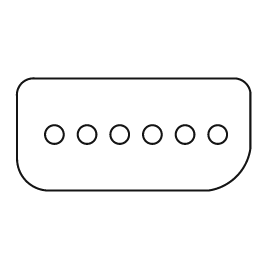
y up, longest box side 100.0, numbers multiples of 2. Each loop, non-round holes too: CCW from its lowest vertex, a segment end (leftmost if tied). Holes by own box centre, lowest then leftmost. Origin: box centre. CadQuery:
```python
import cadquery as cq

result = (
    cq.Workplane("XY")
    .moveTo(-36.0, -24.0)
    .lineTo(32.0, -24.0)
    .threePointArc((44.0, -18.0), (50.0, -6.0))
    .lineTo(50.0, 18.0)
    .threePointArc((48.0, 22.0), (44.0, 24.0))
    .lineTo(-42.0, 24.0)
    .threePointArc((-48.0, 22.0), (-50.0, 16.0))
    .lineTo(-50.0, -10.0)
    .threePointArc((-46.0, -20.0), (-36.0, -24.0))
    .close()
    .moveTo(-34.0, 0.0)
    .circle(4.0)
    .moveTo(-20.0, 0.0)
    .circle(4.0)
    .moveTo(-6.0, 0.0)
    .circle(4.0)
    .moveTo(8.0, 0.0)
    .circle(4.0)
    .moveTo(22.0, 0.0)
    .circle(4.0)
    .moveTo(36.0, 0.0)
    .circle(4.0)
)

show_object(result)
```